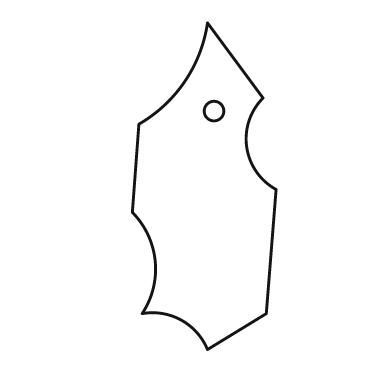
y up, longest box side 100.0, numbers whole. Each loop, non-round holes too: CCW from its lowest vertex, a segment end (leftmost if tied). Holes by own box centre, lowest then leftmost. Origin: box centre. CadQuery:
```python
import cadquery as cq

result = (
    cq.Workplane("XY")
    .moveTo(1.0, -50.0)
    .lineTo(19.0, -39.0)
    .lineTo(22.0, -1.0)
    .threePointArc((13.0, 12.0), (18.0, 27.0))
    .lineTo(1.0, 50.0)
    .threePointArc((-6.0, 32.0), (-20.0, 19.0))
    .lineTo(-22.0, -8.0)
    .threePointArc((-15.0, -23.0), (-19.0, -39.0))
    .threePointArc((-7.0, -41.0), (1.0, -50.0))
    .close()
    .moveTo(3.0, 23.0)
    .circle(3.0)
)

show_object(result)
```